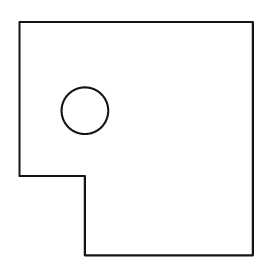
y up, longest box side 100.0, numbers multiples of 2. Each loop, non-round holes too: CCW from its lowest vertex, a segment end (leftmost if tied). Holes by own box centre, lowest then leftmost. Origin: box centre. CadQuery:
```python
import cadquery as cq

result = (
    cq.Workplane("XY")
    .moveTo(-22.0, -50.0)
    .lineTo(50.0, -50.0)
    .lineTo(50.0, 50.0)
    .lineTo(-50.0, 50.0)
    .lineTo(-50.0, -16.0)
    .lineTo(-22.0, -16.0)
    .close()
    .moveTo(-22.0, 12.0)
    .circle(10.0)
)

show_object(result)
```